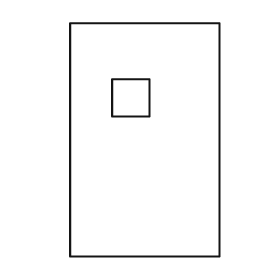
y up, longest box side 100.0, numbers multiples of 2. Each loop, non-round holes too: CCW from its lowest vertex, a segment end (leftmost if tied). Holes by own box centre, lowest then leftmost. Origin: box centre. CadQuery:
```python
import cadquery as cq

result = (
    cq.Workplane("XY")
    .moveTo(-32.0, -50.0)
    .lineTo(32.0, -50.0)
    .lineTo(32.0, 50.0)
    .lineTo(-32.0, 50.0)
    .close()
    .moveTo(-14.0, 10.0)
    .lineTo(2.0, 10.0)
    .lineTo(2.0, 26.0)
    .lineTo(-14.0, 26.0)
    .close()
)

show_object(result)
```